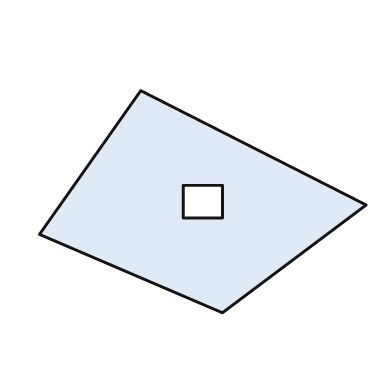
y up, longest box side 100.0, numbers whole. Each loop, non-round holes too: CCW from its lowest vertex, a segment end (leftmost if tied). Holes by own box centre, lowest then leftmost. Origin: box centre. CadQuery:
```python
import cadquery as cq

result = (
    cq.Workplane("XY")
    .moveTo(6.0, -34.0)
    .lineTo(50.0, -1.0)
    .lineTo(-19.0, 34.0)
    .lineTo(-50.0, -10.0)
    .close()
    .moveTo(-6.0, -5.0)
    .lineTo(6.0, -5.0)
    .lineTo(6.0, 5.0)
    .lineTo(-6.0, 5.0)
    .close()
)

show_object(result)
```